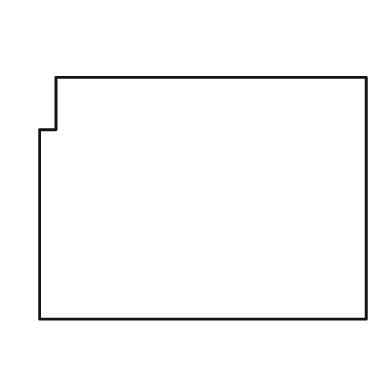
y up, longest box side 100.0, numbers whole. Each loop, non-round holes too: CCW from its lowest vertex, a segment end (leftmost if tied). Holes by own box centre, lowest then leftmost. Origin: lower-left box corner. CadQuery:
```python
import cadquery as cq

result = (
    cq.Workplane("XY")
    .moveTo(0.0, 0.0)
    .lineTo(100.0, 0.0)
    .lineTo(100.0, 74.0)
    .lineTo(5.0, 74.0)
    .lineTo(5.0, 58.0)
    .lineTo(0.0, 58.0)
    .close()
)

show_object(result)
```